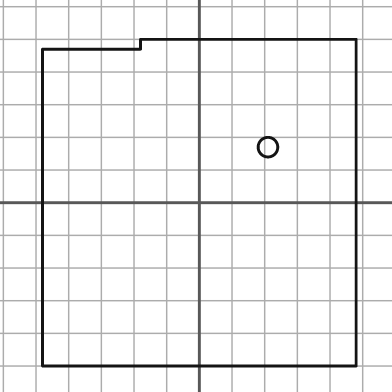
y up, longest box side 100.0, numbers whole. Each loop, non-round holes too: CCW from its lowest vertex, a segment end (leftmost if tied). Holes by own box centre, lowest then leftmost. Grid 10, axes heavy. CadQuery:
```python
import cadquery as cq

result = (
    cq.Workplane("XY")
    .moveTo(-48.0, -50.0)
    .lineTo(48.0, -50.0)
    .lineTo(48.0, 50.0)
    .lineTo(-18.0, 50.0)
    .lineTo(-18.0, 47.0)
    .lineTo(-48.0, 47.0)
    .close()
    .moveTo(21.0, 17.0)
    .circle(3.0)
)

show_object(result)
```